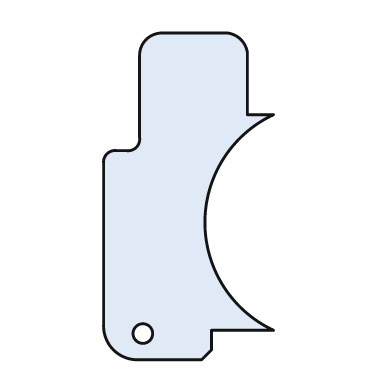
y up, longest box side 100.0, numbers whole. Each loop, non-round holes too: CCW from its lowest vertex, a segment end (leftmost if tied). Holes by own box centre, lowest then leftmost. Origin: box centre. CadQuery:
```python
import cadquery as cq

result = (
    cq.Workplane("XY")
    .moveTo(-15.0, -50.0)
    .lineTo(4.0, -50.0)
    .lineTo(7.0, -47.0)
    .lineTo(7.0, -41.0)
    .lineTo(26.0, -41.0)
    .threePointArc((5.0, -8.0), (26.0, 25.0))
    .lineTo(18.0, 25.0)
    .lineTo(18.0, 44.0)
    .threePointArc((16.0, 48.0), (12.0, 50.0))
    .lineTo(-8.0, 50.0)
    .threePointArc((-13.0, 48.0), (-15.0, 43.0))
    .lineTo(-15.0, 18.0)
    .threePointArc((-16.0, 15.0), (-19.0, 14.0))
    .lineTo(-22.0, 14.0)
    .threePointArc((-25.0, 13.0), (-26.0, 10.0))
    .lineTo(-26.0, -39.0)
    .threePointArc((-23.0, -47.0), (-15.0, -50.0))
    .close()
    .moveTo(-14.0, -42.0)
    .circle(3.0)
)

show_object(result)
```